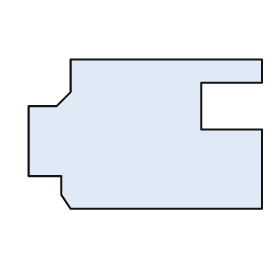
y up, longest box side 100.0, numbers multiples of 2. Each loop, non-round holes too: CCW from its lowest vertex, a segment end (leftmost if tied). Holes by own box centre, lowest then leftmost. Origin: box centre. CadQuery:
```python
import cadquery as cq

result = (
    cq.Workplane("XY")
    .moveTo(-32.0, -32.0)
    .lineTo(50.0, -32.0)
    .lineTo(50.0, 2.0)
    .lineTo(24.0, 2.0)
    .lineTo(24.0, 22.0)
    .lineTo(50.0, 22.0)
    .lineTo(50.0, 32.0)
    .lineTo(-32.0, 32.0)
    .lineTo(-32.0, 18.0)
    .lineTo(-38.0, 12.0)
    .lineTo(-50.0, 12.0)
    .lineTo(-50.0, -18.0)
    .lineTo(-36.0, -18.0)
    .lineTo(-36.0, -26.0)
    .close()
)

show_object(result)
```